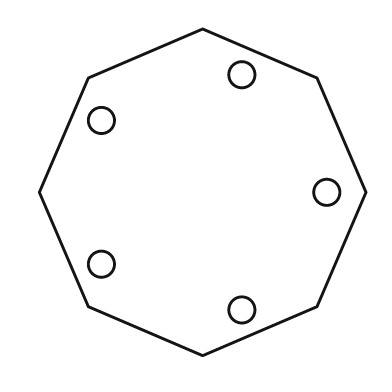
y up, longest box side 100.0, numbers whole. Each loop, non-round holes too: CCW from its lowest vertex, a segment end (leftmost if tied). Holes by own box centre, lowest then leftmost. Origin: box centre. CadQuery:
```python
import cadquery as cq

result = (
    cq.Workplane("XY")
    .moveTo(0.0, -50.0)
    .lineTo(35.0, -35.0)
    .lineTo(50.0, 0.0)
    .lineTo(35.0, 35.0)
    .lineTo(0.0, 50.0)
    .lineTo(-35.0, 35.0)
    .lineTo(-50.0, 0.0)
    .lineTo(-35.0, -35.0)
    .close()
    .moveTo(12.0, -36.0)
    .circle(4.0)
    .moveTo(-31.0, -22.0)
    .circle(4.0)
    .moveTo(38.0, 0.0)
    .circle(4.0)
    .moveTo(-31.0, 22.0)
    .circle(4.0)
    .moveTo(12.0, 36.0)
    .circle(4.0)
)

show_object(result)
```